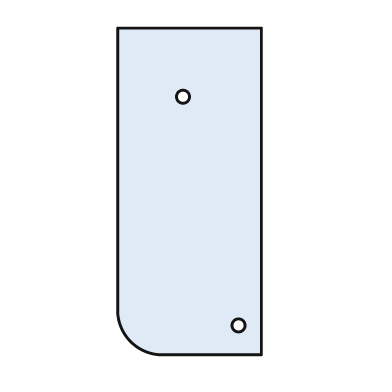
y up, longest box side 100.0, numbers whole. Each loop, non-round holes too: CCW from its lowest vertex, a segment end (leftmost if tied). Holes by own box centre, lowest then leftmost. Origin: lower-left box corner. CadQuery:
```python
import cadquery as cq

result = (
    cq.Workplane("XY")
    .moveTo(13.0, 0.0)
    .lineTo(44.0, 0.0)
    .lineTo(44.0, 100.0)
    .lineTo(0.0, 100.0)
    .lineTo(0.0, 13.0)
    .threePointArc((4.0, 4.0), (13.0, 0.0))
    .close()
    .moveTo(37.0, 9.0)
    .circle(2.0)
    .moveTo(20.0, 79.0)
    .circle(2.0)
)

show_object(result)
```